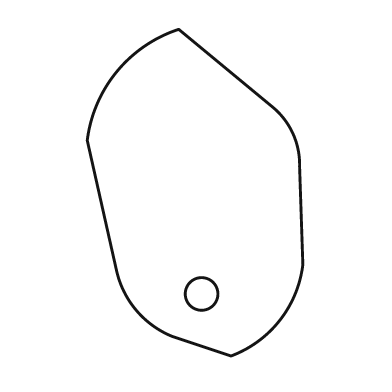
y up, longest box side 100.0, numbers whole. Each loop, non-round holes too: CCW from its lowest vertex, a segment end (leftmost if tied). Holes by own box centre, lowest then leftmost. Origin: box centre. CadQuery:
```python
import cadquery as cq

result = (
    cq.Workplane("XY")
    .moveTo(11.0, -50.0)
    .threePointArc((26.0, -39.0), (33.0, -22.0))
    .lineTo(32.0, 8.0)
    .threePointArc((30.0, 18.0), (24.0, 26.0))
    .lineTo(-5.0, 50.0)
    .threePointArc((-24.0, 37.0), (-33.0, 16.0))
    .lineTo(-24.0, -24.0)
    .threePointArc((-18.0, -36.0), (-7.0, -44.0))
    .close()
    .moveTo(2.0, -31.0)
    .circle(5.0)
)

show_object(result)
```